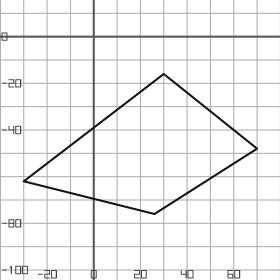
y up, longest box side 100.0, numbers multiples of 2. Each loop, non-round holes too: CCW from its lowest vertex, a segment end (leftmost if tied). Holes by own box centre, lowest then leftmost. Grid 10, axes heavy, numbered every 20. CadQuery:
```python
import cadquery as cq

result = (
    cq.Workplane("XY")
    .moveTo(26.0, -76.0)
    .lineTo(70.0, -48.0)
    .lineTo(30.0, -16.0)
    .lineTo(-30.0, -62.0)
    .close()
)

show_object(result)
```